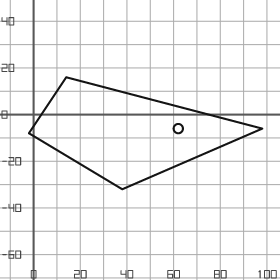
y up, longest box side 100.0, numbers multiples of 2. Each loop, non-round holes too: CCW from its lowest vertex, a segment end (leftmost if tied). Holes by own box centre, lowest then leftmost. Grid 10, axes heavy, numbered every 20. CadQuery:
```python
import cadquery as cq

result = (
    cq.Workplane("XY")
    .moveTo(38.0, -32.0)
    .lineTo(98.0, -6.0)
    .lineTo(14.0, 16.0)
    .lineTo(-2.0, -8.0)
    .close()
    .moveTo(62.0, -6.0)
    .circle(2.0)
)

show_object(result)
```